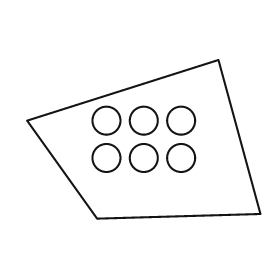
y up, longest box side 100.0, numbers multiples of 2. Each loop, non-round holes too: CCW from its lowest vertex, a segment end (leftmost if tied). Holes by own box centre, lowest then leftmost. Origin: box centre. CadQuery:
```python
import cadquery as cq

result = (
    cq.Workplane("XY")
    .moveTo(-20.0, -34.0)
    .lineTo(50.0, -32.0)
    .lineTo(32.0, 34.0)
    .lineTo(-50.0, 8.0)
    .close()
    .moveTo(-16.0, -8.0)
    .circle(6.0)
    .moveTo(0.0, -8.0)
    .circle(6.0)
    .moveTo(16.0, -8.0)
    .circle(6.0)
    .moveTo(-16.0, 8.0)
    .circle(6.0)
    .moveTo(0.0, 8.0)
    .circle(6.0)
    .moveTo(16.0, 8.0)
    .circle(6.0)
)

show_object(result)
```